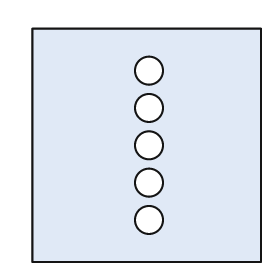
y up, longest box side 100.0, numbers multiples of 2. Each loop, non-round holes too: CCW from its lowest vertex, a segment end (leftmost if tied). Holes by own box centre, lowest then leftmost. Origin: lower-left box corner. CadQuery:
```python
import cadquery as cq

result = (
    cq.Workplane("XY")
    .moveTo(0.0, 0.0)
    .lineTo(98.0, 0.0)
    .lineTo(98.0, 100.0)
    .lineTo(0.0, 100.0)
    .close()
    .moveTo(50.0, 18.0)
    .circle(6.0)
    .moveTo(50.0, 34.0)
    .circle(6.0)
    .moveTo(50.0, 50.0)
    .circle(6.0)
    .moveTo(50.0, 66.0)
    .circle(6.0)
    .moveTo(50.0, 82.0)
    .circle(6.0)
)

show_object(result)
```